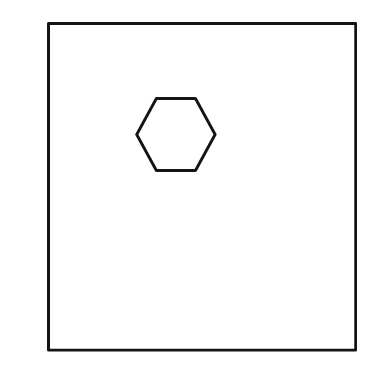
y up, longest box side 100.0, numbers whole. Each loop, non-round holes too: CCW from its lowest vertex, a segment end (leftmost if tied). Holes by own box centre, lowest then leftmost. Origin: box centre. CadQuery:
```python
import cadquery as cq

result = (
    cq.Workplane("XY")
    .moveTo(-47.0, -50.0)
    .lineTo(47.0, -50.0)
    .lineTo(47.0, 50.0)
    .lineTo(-47.0, 50.0)
    .close()
    .moveTo(-14.0, 5.0)
    .lineTo(-2.0, 5.0)
    .lineTo(4.0, 16.0)
    .lineTo(-2.0, 27.0)
    .lineTo(-14.0, 27.0)
    .lineTo(-20.0, 16.0)
    .close()
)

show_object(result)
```